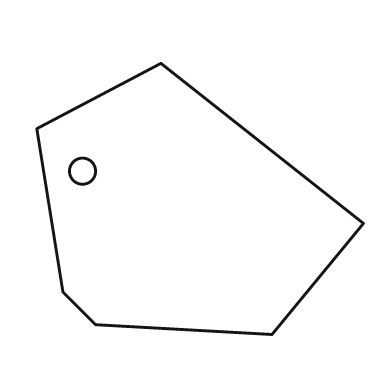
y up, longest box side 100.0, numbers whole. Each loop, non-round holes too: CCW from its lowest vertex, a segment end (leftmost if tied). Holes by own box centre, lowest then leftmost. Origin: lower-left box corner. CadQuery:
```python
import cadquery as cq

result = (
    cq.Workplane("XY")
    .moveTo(72.0, 0.0)
    .lineTo(100.0, 34.0)
    .lineTo(38.0, 83.0)
    .lineTo(0.0, 63.0)
    .lineTo(8.0, 13.0)
    .lineTo(18.0, 3.0)
    .close()
    .moveTo(14.0, 50.0)
    .circle(4.0)
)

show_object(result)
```